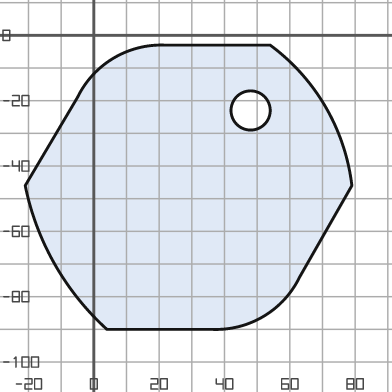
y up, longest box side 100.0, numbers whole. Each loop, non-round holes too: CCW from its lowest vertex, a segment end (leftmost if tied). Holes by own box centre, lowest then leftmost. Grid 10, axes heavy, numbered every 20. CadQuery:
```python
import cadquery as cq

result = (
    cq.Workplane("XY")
    .moveTo(4.0, -90.0)
    .lineTo(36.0, -90.0)
    .threePointArc((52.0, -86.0), (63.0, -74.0))
    .lineTo(79.0, -46.0)
    .threePointArc((71.0, -22.0), (54.0, -3.0))
    .lineTo(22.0, -3.0)
    .threePointArc((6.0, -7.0), (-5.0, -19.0))
    .lineTo(-21.0, -46.0)
    .threePointArc((-12.0, -70.0), (4.0, -90.0))
    .close()
    .moveTo(48.0, -23.0)
    .circle(6.0)
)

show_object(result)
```